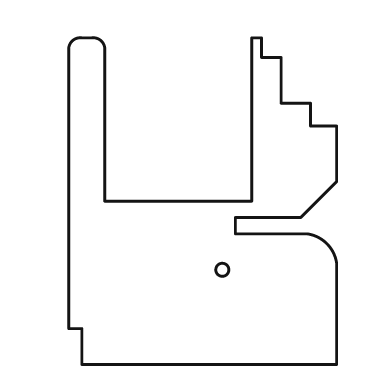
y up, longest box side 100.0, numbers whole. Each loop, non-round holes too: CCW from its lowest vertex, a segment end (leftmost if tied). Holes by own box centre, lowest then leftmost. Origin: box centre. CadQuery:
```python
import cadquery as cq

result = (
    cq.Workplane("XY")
    .moveTo(-37.0, -50.0)
    .lineTo(41.0, -50.0)
    .lineTo(41.0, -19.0)
    .threePointArc((38.0, -13.0), (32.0, -10.0))
    .lineTo(10.0, -10.0)
    .lineTo(10.0, -5.0)
    .lineTo(30.0, -5.0)
    .lineTo(41.0, 6.0)
    .lineTo(41.0, 23.0)
    .lineTo(33.0, 23.0)
    .lineTo(33.0, 30.0)
    .lineTo(24.0, 30.0)
    .lineTo(24.0, 44.0)
    .lineTo(18.0, 44.0)
    .lineTo(18.0, 50.0)
    .lineTo(15.0, 50.0)
    .lineTo(15.0, 0.0)
    .lineTo(-30.0, 0.0)
    .lineTo(-30.0, 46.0)
    .threePointArc((-31.0, 49.0), (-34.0, 50.0))
    .lineTo(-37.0, 50.0)
    .threePointArc((-40.0, 49.0), (-41.0, 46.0))
    .lineTo(-41.0, -39.0)
    .lineTo(-37.0, -39.0)
    .close()
    .moveTo(6.0, -21.0)
    .circle(2.0)
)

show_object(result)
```